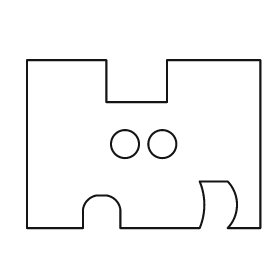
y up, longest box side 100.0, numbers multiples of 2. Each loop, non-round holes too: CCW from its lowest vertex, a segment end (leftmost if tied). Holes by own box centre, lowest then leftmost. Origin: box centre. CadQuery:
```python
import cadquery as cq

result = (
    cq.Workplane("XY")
    .moveTo(-50.0, -36.0)
    .lineTo(-26.0, -36.0)
    .lineTo(-26.0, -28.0)
    .threePointArc((-24.0, -24.0), (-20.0, -22.0))
    .lineTo(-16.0, -22.0)
    .threePointArc((-12.0, -24.0), (-10.0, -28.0))
    .lineTo(-10.0, -36.0)
    .lineTo(24.0, -36.0)
    .threePointArc((26.0, -26.0), (24.0, -16.0))
    .lineTo(36.0, -16.0)
    .threePointArc((40.0, -26.0), (36.0, -36.0))
    .lineTo(50.0, -36.0)
    .lineTo(50.0, 36.0)
    .lineTo(10.0, 36.0)
    .lineTo(10.0, 18.0)
    .lineTo(-16.0, 18.0)
    .lineTo(-16.0, 36.0)
    .lineTo(-50.0, 36.0)
    .close()
    .moveTo(-8.0, 0.0)
    .circle(6.0)
    .moveTo(8.0, 0.0)
    .circle(6.0)
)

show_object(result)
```